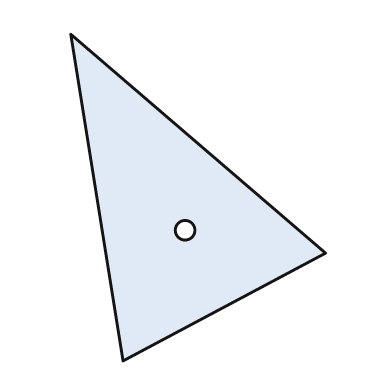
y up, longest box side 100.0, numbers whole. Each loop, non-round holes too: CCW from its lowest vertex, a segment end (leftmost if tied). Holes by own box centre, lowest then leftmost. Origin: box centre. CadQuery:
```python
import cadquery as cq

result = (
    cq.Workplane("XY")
    .moveTo(-23.0, -50.0)
    .lineTo(39.0, -17.0)
    .lineTo(-39.0, 50.0)
    .close()
    .moveTo(-4.0, -10.0)
    .circle(3.0)
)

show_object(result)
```